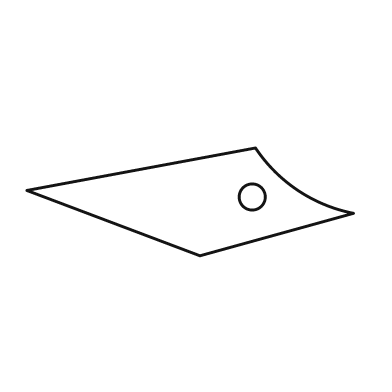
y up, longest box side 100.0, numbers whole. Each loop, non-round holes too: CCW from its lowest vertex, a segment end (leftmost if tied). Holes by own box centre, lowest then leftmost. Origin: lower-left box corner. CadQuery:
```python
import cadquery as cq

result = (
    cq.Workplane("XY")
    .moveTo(53.0, 0.0)
    .lineTo(100.0, 13.0)
    .threePointArc((83.0, 20.0), (70.0, 33.0))
    .lineTo(0.0, 20.0)
    .close()
    .moveTo(69.0, 18.0)
    .circle(4.0)
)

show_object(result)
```